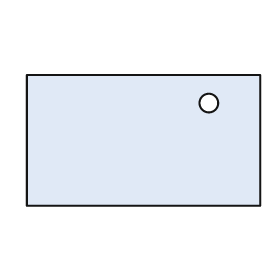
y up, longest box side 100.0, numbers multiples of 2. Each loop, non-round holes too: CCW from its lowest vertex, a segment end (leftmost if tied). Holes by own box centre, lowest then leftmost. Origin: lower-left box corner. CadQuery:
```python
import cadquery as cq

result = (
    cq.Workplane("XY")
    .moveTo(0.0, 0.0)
    .lineTo(100.0, 0.0)
    .lineTo(100.0, 56.0)
    .lineTo(0.0, 56.0)
    .close()
    .moveTo(78.0, 44.0)
    .circle(4.0)
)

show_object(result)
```